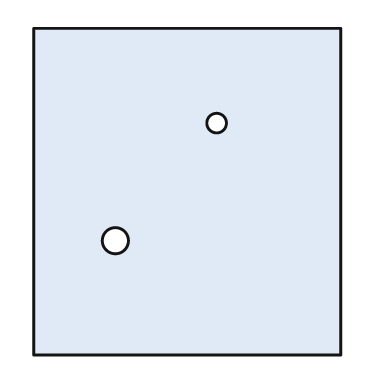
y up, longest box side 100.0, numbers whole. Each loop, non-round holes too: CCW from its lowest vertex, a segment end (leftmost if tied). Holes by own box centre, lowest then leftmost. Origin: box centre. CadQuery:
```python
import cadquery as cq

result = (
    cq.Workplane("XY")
    .moveTo(-47.0, -50.0)
    .lineTo(47.0, -50.0)
    .lineTo(47.0, 50.0)
    .lineTo(-47.0, 50.0)
    .close()
    .moveTo(-22.0, -15.0)
    .circle(4.0)
    .moveTo(9.0, 21.0)
    .circle(3.0)
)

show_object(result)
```